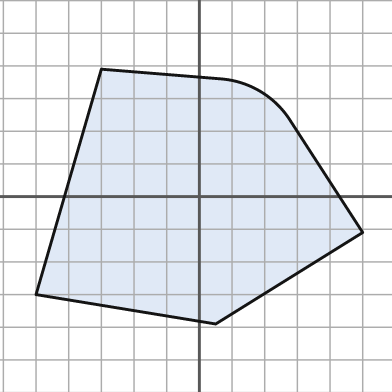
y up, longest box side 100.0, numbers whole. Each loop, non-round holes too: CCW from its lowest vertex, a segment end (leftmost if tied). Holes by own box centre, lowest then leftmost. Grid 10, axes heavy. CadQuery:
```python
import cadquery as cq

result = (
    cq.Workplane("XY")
    .moveTo(5.0, -39.0)
    .lineTo(50.0, -11.0)
    .lineTo(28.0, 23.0)
    .threePointArc((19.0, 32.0), (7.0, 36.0))
    .lineTo(-30.0, 39.0)
    .lineTo(-50.0, -30.0)
    .close()
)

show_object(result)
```